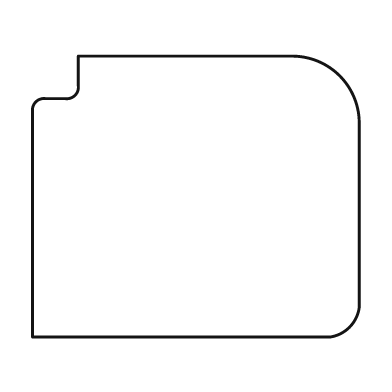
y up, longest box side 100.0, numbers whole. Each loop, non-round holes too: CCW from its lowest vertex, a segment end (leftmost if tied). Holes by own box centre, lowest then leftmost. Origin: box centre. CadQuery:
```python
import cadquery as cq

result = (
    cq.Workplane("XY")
    .moveTo(-50.0, -43.0)
    .lineTo(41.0, -43.0)
    .threePointArc((47.0, -40.0), (50.0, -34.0))
    .lineTo(50.0, 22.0)
    .threePointArc((44.0, 37.0), (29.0, 43.0))
    .lineTo(-36.0, 43.0)
    .lineTo(-36.0, 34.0)
    .threePointArc((-37.0, 31.0), (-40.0, 30.0))
    .lineTo(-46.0, 30.0)
    .threePointArc((-49.0, 29.0), (-50.0, 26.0))
    .close()
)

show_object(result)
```